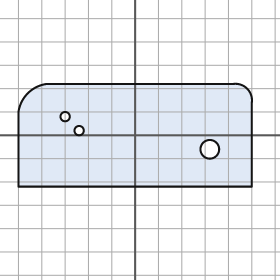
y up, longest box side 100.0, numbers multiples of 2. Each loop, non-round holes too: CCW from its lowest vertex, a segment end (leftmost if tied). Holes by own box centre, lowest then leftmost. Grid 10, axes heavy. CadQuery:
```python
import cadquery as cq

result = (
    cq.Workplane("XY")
    .moveTo(-50.0, -22.0)
    .lineTo(50.0, -22.0)
    .lineTo(50.0, 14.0)
    .threePointArc((48.0, 20.0), (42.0, 22.0))
    .lineTo(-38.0, 22.0)
    .threePointArc((-46.0, 18.0), (-50.0, 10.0))
    .close()
    .moveTo(32.0, -6.0)
    .circle(4.0)
    .moveTo(-24.0, 2.0)
    .circle(2.0)
    .moveTo(-30.0, 8.0)
    .circle(2.0)
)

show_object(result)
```